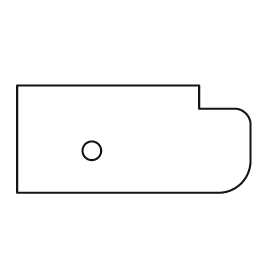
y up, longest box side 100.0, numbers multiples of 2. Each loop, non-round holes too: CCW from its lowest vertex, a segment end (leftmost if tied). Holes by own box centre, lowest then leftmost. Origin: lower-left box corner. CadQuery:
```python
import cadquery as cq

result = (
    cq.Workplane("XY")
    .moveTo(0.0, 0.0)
    .lineTo(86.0, 0.0)
    .threePointArc((96.0, 4.0), (100.0, 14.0))
    .lineTo(100.0, 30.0)
    .threePointArc((98.0, 34.0), (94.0, 36.0))
    .lineTo(78.0, 36.0)
    .lineTo(78.0, 46.0)
    .lineTo(0.0, 46.0)
    .close()
    .moveTo(32.0, 18.0)
    .circle(4.0)
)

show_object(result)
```